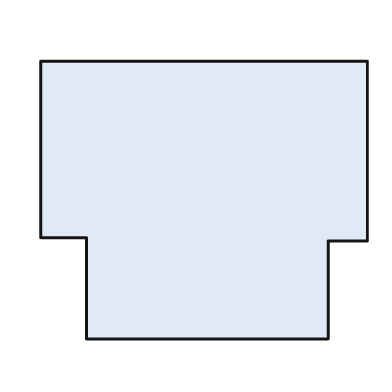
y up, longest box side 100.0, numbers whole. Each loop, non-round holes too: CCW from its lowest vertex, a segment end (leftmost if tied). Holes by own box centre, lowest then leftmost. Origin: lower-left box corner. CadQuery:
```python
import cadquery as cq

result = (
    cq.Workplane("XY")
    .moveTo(14.0, 0.0)
    .lineTo(88.0, 0.0)
    .lineTo(88.0, 30.0)
    .lineTo(100.0, 30.0)
    .lineTo(100.0, 85.0)
    .lineTo(0.0, 85.0)
    .lineTo(0.0, 31.0)
    .lineTo(14.0, 31.0)
    .close()
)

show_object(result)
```